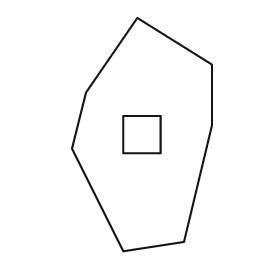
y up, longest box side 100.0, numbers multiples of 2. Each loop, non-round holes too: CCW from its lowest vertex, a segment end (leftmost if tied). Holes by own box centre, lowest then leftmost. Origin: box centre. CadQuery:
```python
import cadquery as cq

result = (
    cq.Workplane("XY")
    .moveTo(-8.0, -50.0)
    .lineTo(18.0, -46.0)
    .lineTo(30.0, 4.0)
    .lineTo(30.0, 30.0)
    .lineTo(-2.0, 50.0)
    .lineTo(-24.0, 18.0)
    .lineTo(-30.0, -6.0)
    .close()
    .moveTo(-8.0, -8.0)
    .lineTo(8.0, -8.0)
    .lineTo(8.0, 8.0)
    .lineTo(-8.0, 8.0)
    .close()
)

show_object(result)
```